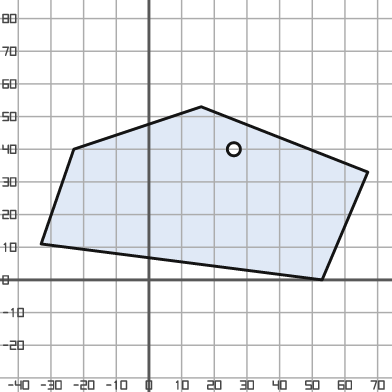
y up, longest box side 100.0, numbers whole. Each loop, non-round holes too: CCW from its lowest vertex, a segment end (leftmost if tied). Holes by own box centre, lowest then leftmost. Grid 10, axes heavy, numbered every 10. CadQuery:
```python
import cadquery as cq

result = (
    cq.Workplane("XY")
    .moveTo(53.0, 0.0)
    .lineTo(67.0, 33.0)
    .lineTo(16.0, 53.0)
    .lineTo(-23.0, 40.0)
    .lineTo(-33.0, 11.0)
    .close()
    .moveTo(26.0, 40.0)
    .circle(2.0)
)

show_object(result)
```